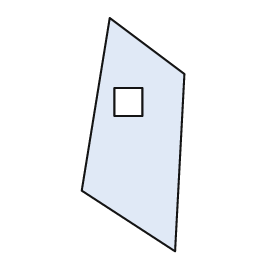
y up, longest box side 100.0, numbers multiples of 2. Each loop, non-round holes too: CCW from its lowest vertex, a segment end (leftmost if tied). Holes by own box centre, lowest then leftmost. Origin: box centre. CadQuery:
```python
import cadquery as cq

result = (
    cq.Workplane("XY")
    .moveTo(18.0, -50.0)
    .lineTo(22.0, 26.0)
    .lineTo(-10.0, 50.0)
    .lineTo(-22.0, -24.0)
    .close()
    .moveTo(-8.0, 8.0)
    .lineTo(4.0, 8.0)
    .lineTo(4.0, 20.0)
    .lineTo(-8.0, 20.0)
    .close()
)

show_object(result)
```